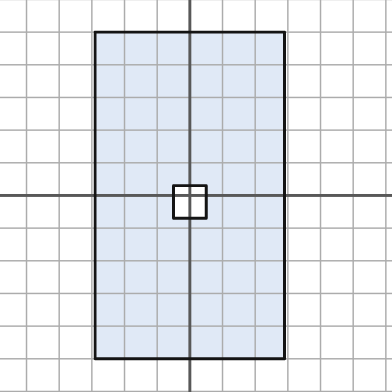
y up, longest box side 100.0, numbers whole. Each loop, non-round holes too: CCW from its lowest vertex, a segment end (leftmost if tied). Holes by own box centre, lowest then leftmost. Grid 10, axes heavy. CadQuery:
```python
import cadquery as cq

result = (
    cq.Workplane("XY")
    .moveTo(-29.0, -50.0)
    .lineTo(29.0, -50.0)
    .lineTo(29.0, 50.0)
    .lineTo(-29.0, 50.0)
    .close()
    .moveTo(-5.0, -7.0)
    .lineTo(5.0, -7.0)
    .lineTo(5.0, 3.0)
    .lineTo(-5.0, 3.0)
    .close()
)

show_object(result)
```